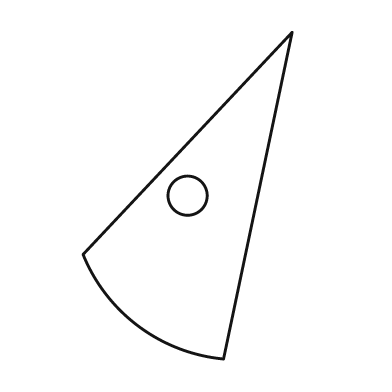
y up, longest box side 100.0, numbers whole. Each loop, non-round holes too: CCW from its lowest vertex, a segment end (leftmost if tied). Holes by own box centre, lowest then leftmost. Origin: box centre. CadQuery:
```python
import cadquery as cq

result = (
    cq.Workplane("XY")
    .moveTo(11.0, -50.0)
    .lineTo(32.0, 50.0)
    .lineTo(-32.0, -18.0)
    .threePointArc((-15.0, -40.0), (11.0, -50.0))
    .close()
    .moveTo(0.0, 0.0)
    .circle(6.0)
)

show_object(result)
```